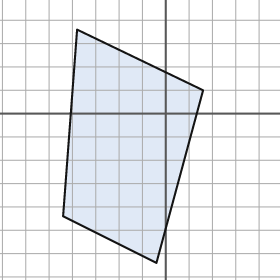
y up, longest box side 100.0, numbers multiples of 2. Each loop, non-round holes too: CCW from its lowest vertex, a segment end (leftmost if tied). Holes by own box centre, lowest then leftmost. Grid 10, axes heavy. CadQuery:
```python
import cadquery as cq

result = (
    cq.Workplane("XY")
    .moveTo(-4.0, -64.0)
    .lineTo(16.0, 10.0)
    .lineTo(-38.0, 36.0)
    .lineTo(-44.0, -44.0)
    .close()
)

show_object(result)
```